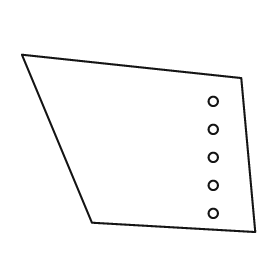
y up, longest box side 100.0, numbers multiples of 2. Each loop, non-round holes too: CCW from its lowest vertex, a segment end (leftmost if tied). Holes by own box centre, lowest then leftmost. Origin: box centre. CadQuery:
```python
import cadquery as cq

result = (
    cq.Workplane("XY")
    .moveTo(50.0, -38.0)
    .lineTo(44.0, 28.0)
    .lineTo(-50.0, 38.0)
    .lineTo(-20.0, -34.0)
    .close()
    .moveTo(32.0, -30.0)
    .circle(2.0)
    .moveTo(32.0, -18.0)
    .circle(2.0)
    .moveTo(32.0, -6.0)
    .circle(2.0)
    .moveTo(32.0, 6.0)
    .circle(2.0)
    .moveTo(32.0, 18.0)
    .circle(2.0)
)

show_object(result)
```